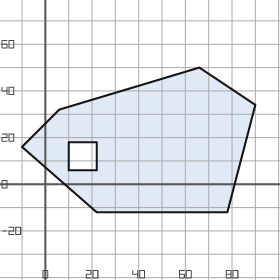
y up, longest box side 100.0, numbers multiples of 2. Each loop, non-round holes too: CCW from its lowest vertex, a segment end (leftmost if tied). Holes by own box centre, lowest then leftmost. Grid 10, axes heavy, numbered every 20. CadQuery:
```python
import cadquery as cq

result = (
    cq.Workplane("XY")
    .moveTo(22.0, -12.0)
    .lineTo(78.0, -12.0)
    .lineTo(90.0, 34.0)
    .lineTo(66.0, 50.0)
    .lineTo(6.0, 32.0)
    .lineTo(-10.0, 16.0)
    .close()
    .moveTo(10.0, 6.0)
    .lineTo(22.0, 6.0)
    .lineTo(22.0, 18.0)
    .lineTo(10.0, 18.0)
    .close()
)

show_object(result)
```